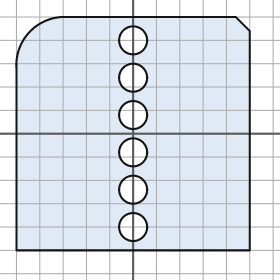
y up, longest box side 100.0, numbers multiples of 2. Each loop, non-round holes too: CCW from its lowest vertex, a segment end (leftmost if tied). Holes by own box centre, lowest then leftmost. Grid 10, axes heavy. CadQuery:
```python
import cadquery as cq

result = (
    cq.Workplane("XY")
    .moveTo(-50.0, -50.0)
    .lineTo(50.0, -50.0)
    .lineTo(50.0, 44.0)
    .lineTo(44.0, 50.0)
    .lineTo(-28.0, 50.0)
    .threePointArc((-44.0, 44.0), (-50.0, 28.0))
    .close()
    .moveTo(0.0, -40.0)
    .circle(6.0)
    .moveTo(0.0, -24.0)
    .circle(6.0)
    .moveTo(0.0, -8.0)
    .circle(6.0)
    .moveTo(0.0, 8.0)
    .circle(6.0)
    .moveTo(0.0, 24.0)
    .circle(6.0)
    .moveTo(0.0, 40.0)
    .circle(6.0)
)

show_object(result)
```